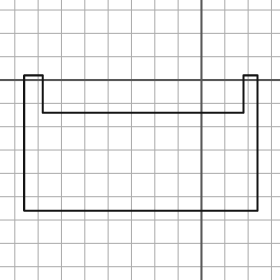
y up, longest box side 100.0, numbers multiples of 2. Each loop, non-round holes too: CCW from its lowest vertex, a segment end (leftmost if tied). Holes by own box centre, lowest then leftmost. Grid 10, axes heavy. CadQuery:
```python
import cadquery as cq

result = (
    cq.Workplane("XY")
    .moveTo(-76.0, -56.0)
    .lineTo(24.0, -56.0)
    .lineTo(24.0, 2.0)
    .lineTo(18.0, 2.0)
    .lineTo(18.0, -14.0)
    .lineTo(-68.0, -14.0)
    .lineTo(-68.0, 2.0)
    .lineTo(-76.0, 2.0)
    .close()
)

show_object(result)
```